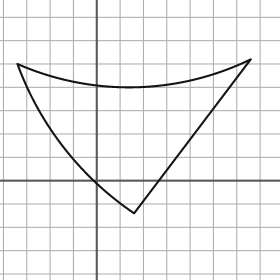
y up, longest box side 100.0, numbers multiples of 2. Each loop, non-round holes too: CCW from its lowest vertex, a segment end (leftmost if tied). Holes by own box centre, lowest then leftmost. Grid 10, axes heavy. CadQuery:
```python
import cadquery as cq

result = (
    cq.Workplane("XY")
    .moveTo(16.0, -14.0)
    .lineTo(66.0, 52.0)
    .threePointArc((16.0, 40.0), (-34.0, 50.0))
    .threePointArc((-14.0, 14.0), (16.0, -14.0))
    .close()
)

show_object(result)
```